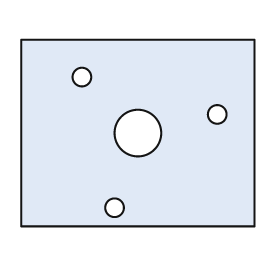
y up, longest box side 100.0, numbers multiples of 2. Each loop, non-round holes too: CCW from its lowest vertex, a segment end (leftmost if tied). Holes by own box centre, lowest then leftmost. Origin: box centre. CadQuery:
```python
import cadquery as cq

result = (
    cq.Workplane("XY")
    .moveTo(-50.0, -40.0)
    .lineTo(50.0, -40.0)
    .lineTo(50.0, 40.0)
    .lineTo(-50.0, 40.0)
    .close()
    .moveTo(-10.0, -32.0)
    .circle(4.0)
    .moveTo(0.0, 0.0)
    .circle(10.0)
    .moveTo(34.0, 8.0)
    .circle(4.0)
    .moveTo(-24.0, 24.0)
    .circle(4.0)
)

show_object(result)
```